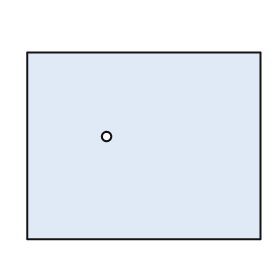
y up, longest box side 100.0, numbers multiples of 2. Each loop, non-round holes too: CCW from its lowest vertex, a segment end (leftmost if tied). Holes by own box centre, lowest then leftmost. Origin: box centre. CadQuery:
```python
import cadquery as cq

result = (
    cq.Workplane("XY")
    .moveTo(-50.0, -40.0)
    .lineTo(50.0, -40.0)
    .lineTo(50.0, 40.0)
    .lineTo(-50.0, 40.0)
    .close()
    .moveTo(-16.0, 4.0)
    .circle(2.0)
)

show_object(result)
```